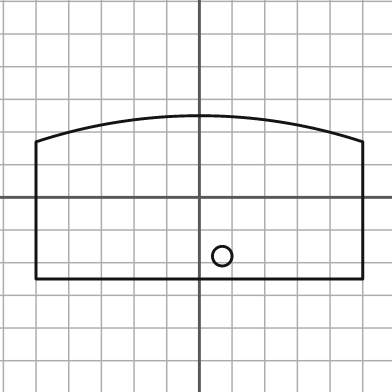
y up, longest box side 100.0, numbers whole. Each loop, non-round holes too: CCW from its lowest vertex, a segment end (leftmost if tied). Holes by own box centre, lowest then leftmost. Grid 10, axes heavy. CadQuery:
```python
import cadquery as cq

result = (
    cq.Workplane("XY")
    .moveTo(-50.0, -25.0)
    .lineTo(50.0, -25.0)
    .lineTo(50.0, 17.0)
    .threePointArc((0.0, 25.0), (-50.0, 17.0))
    .close()
    .moveTo(7.0, -18.0)
    .circle(3.0)
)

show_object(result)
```